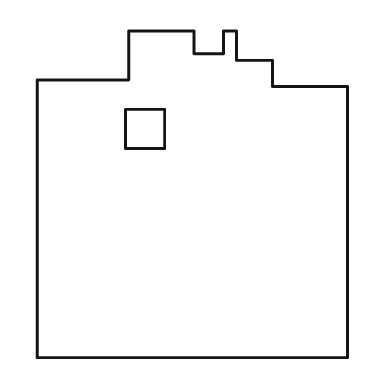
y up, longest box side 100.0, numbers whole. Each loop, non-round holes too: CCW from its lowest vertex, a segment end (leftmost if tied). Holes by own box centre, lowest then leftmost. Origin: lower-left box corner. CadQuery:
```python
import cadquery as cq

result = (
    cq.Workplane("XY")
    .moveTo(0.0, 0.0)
    .lineTo(95.0, 0.0)
    .lineTo(95.0, 83.0)
    .lineTo(72.0, 83.0)
    .lineTo(72.0, 91.0)
    .lineTo(61.0, 91.0)
    .lineTo(61.0, 100.0)
    .lineTo(57.0, 100.0)
    .lineTo(57.0, 93.0)
    .lineTo(48.0, 93.0)
    .lineTo(48.0, 100.0)
    .lineTo(28.0, 100.0)
    .lineTo(28.0, 85.0)
    .lineTo(0.0, 85.0)
    .close()
    .moveTo(27.0, 64.0)
    .lineTo(39.0, 64.0)
    .lineTo(39.0, 76.0)
    .lineTo(27.0, 76.0)
    .close()
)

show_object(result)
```